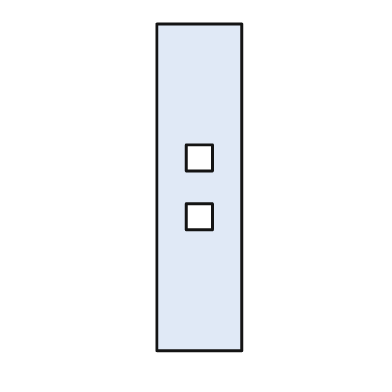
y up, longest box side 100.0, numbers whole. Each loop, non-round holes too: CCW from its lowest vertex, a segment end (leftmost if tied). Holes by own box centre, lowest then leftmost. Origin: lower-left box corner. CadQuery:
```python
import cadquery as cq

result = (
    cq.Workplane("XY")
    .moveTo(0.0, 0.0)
    .lineTo(26.0, 0.0)
    .lineTo(26.0, 100.0)
    .lineTo(0.0, 100.0)
    .close()
    .moveTo(9.0, 37.0)
    .lineTo(17.0, 37.0)
    .lineTo(17.0, 45.0)
    .lineTo(9.0, 45.0)
    .close()
    .moveTo(9.0, 55.0)
    .lineTo(17.0, 55.0)
    .lineTo(17.0, 63.0)
    .lineTo(9.0, 63.0)
    .close()
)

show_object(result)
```